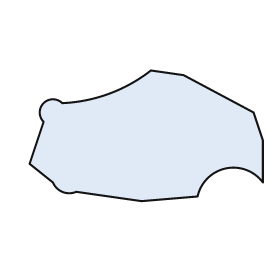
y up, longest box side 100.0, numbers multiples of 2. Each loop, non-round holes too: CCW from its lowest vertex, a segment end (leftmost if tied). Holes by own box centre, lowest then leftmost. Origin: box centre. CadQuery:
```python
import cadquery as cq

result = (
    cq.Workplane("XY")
    .moveTo(-2.0, -28.0)
    .lineTo(22.0, -26.0)
    .threePointArc((34.0, -14.0), (50.0, -20.0))
    .lineTo(50.0, -2.0)
    .lineTo(46.0, 10.0)
    .lineTo(16.0, 26.0)
    .lineTo(2.0, 28.0)
    .threePointArc((-16.0, 18.0), (-36.0, 14.0))
    .threePointArc((-44.0, 14.0), (-44.0, 6.0))
    .lineTo(-50.0, -12.0)
    .lineTo(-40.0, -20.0)
    .threePointArc((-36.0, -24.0), (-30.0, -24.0))
    .close()
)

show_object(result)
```